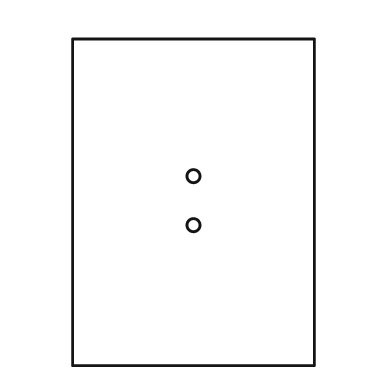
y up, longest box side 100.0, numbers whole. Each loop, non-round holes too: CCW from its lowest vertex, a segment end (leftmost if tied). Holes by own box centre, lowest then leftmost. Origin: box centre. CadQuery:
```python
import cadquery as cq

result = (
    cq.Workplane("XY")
    .moveTo(-37.0, -50.0)
    .lineTo(37.0, -50.0)
    .lineTo(37.0, 50.0)
    .lineTo(-37.0, 50.0)
    .close()
    .moveTo(0.0, -7.0)
    .circle(2.0)
    .moveTo(0.0, 8.0)
    .circle(2.0)
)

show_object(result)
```